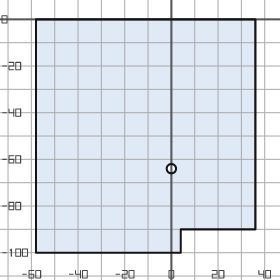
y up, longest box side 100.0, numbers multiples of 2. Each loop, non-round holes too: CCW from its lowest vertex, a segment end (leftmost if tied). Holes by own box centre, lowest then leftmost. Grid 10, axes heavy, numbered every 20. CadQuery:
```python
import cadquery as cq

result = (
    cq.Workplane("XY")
    .moveTo(-58.0, -100.0)
    .lineTo(4.0, -100.0)
    .lineTo(4.0, -90.0)
    .lineTo(36.0, -90.0)
    .lineTo(36.0, 0.0)
    .lineTo(-58.0, 0.0)
    .close()
    .moveTo(0.0, -64.0)
    .circle(2.0)
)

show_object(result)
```